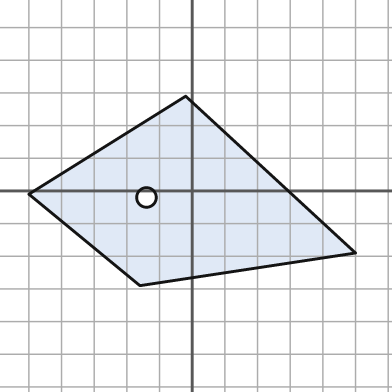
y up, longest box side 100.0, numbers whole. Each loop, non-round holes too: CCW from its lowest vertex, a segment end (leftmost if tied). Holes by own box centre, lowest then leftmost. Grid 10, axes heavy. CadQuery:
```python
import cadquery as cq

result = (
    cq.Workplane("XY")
    .moveTo(-16.0, -29.0)
    .lineTo(50.0, -19.0)
    .lineTo(-2.0, 29.0)
    .lineTo(-50.0, -1.0)
    .close()
    .moveTo(-14.0, -2.0)
    .circle(3.0)
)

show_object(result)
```